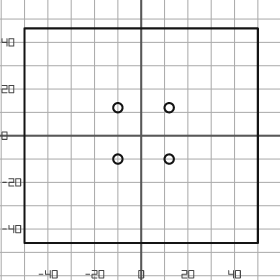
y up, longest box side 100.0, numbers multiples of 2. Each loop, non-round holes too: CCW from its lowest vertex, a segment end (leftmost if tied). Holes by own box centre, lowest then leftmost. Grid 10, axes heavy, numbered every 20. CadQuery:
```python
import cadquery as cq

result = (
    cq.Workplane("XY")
    .moveTo(-50.0, -46.0)
    .lineTo(50.0, -46.0)
    .lineTo(50.0, 46.0)
    .lineTo(-50.0, 46.0)
    .close()
    .moveTo(-10.0, -10.0)
    .circle(2.0)
    .moveTo(12.0, -10.0)
    .circle(2.0)
    .moveTo(-10.0, 12.0)
    .circle(2.0)
    .moveTo(12.0, 12.0)
    .circle(2.0)
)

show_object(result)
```